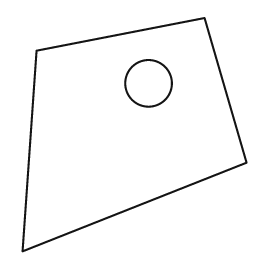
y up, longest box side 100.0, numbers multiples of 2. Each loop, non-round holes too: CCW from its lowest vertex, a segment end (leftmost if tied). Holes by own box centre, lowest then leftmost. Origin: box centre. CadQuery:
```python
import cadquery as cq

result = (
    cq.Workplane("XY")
    .moveTo(-48.0, -50.0)
    .lineTo(48.0, -12.0)
    .lineTo(30.0, 50.0)
    .lineTo(-42.0, 36.0)
    .close()
    .moveTo(6.0, 22.0)
    .circle(10.0)
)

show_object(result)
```